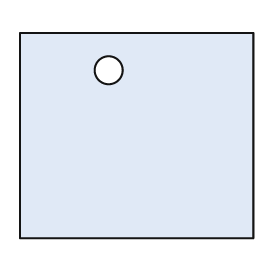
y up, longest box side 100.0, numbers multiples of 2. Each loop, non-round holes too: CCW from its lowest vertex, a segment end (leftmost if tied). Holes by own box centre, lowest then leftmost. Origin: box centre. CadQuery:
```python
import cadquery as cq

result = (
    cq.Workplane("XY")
    .moveTo(-50.0, -44.0)
    .lineTo(50.0, -44.0)
    .lineTo(50.0, 44.0)
    .lineTo(-50.0, 44.0)
    .close()
    .moveTo(-12.0, 28.0)
    .circle(6.0)
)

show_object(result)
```